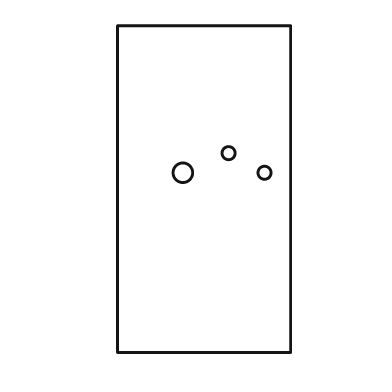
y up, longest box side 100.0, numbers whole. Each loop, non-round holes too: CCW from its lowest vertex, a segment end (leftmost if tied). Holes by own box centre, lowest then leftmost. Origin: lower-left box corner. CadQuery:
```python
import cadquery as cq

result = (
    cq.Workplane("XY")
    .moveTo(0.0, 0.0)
    .lineTo(53.0, 0.0)
    .lineTo(53.0, 100.0)
    .lineTo(0.0, 100.0)
    .close()
    .moveTo(20.0, 55.0)
    .circle(3.0)
    .moveTo(45.0, 55.0)
    .circle(2.0)
    .moveTo(34.0, 61.0)
    .circle(2.0)
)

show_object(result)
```